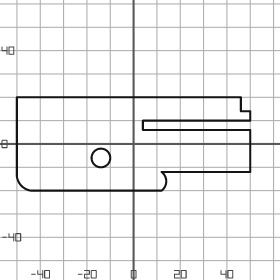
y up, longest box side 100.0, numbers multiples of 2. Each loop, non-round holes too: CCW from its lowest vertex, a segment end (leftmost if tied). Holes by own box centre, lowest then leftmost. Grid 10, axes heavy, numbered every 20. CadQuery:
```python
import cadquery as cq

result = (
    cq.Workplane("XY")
    .moveTo(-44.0, -20.0)
    .lineTo(12.0, -20.0)
    .threePointArc((14.0, -16.0), (12.0, -12.0))
    .lineTo(50.0, -12.0)
    .lineTo(50.0, 6.0)
    .lineTo(4.0, 6.0)
    .lineTo(4.0, 10.0)
    .lineTo(50.0, 10.0)
    .lineTo(50.0, 14.0)
    .lineTo(46.0, 14.0)
    .lineTo(46.0, 20.0)
    .lineTo(-50.0, 20.0)
    .lineTo(-50.0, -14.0)
    .threePointArc((-48.0, -18.0), (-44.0, -20.0))
    .close()
    .moveTo(-14.0, -6.0)
    .circle(4.0)
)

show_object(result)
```